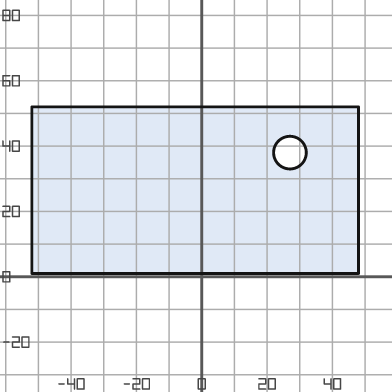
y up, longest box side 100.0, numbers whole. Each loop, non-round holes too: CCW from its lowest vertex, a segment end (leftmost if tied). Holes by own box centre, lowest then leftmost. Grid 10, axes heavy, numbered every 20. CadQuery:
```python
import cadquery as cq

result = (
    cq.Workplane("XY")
    .moveTo(-52.0, 1.0)
    .lineTo(48.0, 1.0)
    .lineTo(48.0, 52.0)
    .lineTo(-52.0, 52.0)
    .close()
    .moveTo(27.0, 38.0)
    .circle(5.0)
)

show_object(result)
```